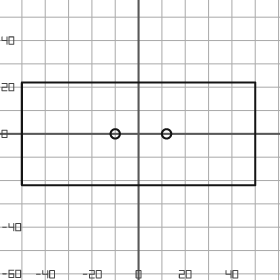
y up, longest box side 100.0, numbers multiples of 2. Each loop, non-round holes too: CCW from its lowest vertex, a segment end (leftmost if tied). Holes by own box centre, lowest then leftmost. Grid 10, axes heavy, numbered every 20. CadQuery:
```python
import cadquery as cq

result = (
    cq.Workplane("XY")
    .moveTo(-50.0, -22.0)
    .lineTo(50.0, -22.0)
    .lineTo(50.0, 22.0)
    .lineTo(-50.0, 22.0)
    .close()
    .moveTo(-10.0, 0.0)
    .circle(2.0)
    .moveTo(12.0, 0.0)
    .circle(2.0)
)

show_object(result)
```